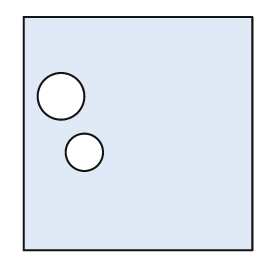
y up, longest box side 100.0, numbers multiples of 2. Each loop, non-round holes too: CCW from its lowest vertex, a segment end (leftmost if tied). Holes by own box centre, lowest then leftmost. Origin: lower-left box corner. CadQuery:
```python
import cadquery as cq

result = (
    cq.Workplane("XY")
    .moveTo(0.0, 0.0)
    .lineTo(98.0, 0.0)
    .lineTo(98.0, 100.0)
    .lineTo(0.0, 100.0)
    .close()
    .moveTo(26.0, 42.0)
    .circle(8.0)
    .moveTo(16.0, 66.0)
    .circle(10.0)
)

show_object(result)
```